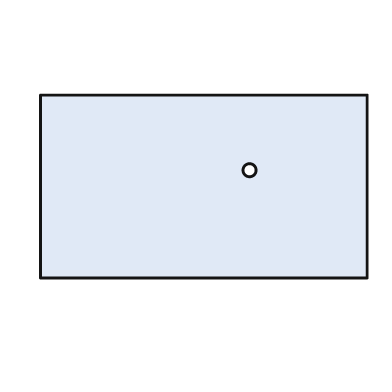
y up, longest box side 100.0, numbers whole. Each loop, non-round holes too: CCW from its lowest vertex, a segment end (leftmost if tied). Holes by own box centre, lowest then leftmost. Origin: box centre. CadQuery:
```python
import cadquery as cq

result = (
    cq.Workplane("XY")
    .moveTo(-50.0, -28.0)
    .lineTo(50.0, -28.0)
    .lineTo(50.0, 28.0)
    .lineTo(-50.0, 28.0)
    .close()
    .moveTo(14.0, 5.0)
    .circle(2.0)
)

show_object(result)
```